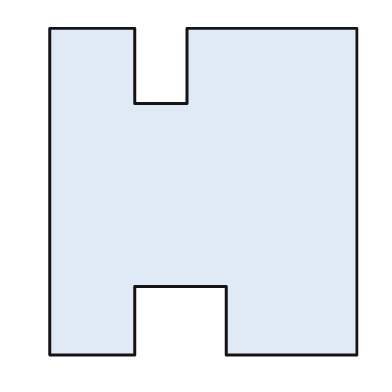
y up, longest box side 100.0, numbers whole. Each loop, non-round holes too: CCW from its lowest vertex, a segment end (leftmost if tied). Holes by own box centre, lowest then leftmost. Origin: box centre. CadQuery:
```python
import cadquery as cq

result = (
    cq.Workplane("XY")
    .moveTo(-47.0, -50.0)
    .lineTo(-21.0, -50.0)
    .lineTo(-21.0, -29.0)
    .lineTo(7.0, -29.0)
    .lineTo(7.0, -50.0)
    .lineTo(47.0, -50.0)
    .lineTo(47.0, 50.0)
    .lineTo(-5.0, 50.0)
    .lineTo(-5.0, 27.0)
    .lineTo(-21.0, 27.0)
    .lineTo(-21.0, 50.0)
    .lineTo(-47.0, 50.0)
    .close()
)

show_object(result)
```